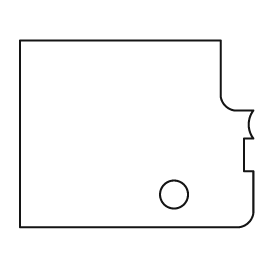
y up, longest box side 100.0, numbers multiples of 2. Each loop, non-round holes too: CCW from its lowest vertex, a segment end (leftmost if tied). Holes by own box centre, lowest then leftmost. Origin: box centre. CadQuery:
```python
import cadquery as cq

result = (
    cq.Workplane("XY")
    .moveTo(-50.0, -40.0)
    .lineTo(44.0, -40.0)
    .threePointArc((48.0, -38.0), (50.0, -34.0))
    .lineTo(50.0, -16.0)
    .lineTo(46.0, -16.0)
    .lineTo(46.0, -2.0)
    .lineTo(50.0, -2.0)
    .threePointArc((48.0, 4.0), (50.0, 10.0))
    .lineTo(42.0, 10.0)
    .threePointArc((38.0, 12.0), (36.0, 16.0))
    .lineTo(36.0, 40.0)
    .lineTo(-50.0, 40.0)
    .close()
    .moveTo(16.0, -26.0)
    .circle(6.0)
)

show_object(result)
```